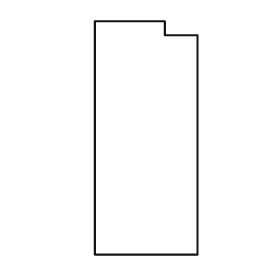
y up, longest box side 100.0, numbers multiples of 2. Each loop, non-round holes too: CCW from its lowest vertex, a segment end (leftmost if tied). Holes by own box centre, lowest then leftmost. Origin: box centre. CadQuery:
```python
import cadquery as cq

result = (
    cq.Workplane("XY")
    .moveTo(-22.0, -50.0)
    .lineTo(22.0, -50.0)
    .lineTo(22.0, 44.0)
    .lineTo(8.0, 44.0)
    .lineTo(8.0, 50.0)
    .lineTo(-22.0, 50.0)
    .close()
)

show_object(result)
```